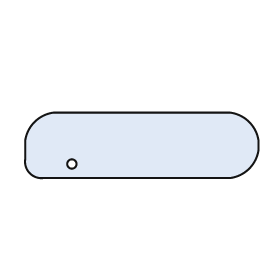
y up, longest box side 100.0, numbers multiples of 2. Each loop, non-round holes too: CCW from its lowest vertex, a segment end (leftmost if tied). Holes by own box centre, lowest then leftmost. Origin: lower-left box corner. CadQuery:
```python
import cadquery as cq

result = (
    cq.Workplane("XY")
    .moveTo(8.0, 0.0)
    .lineTo(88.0, 0.0)
    .threePointArc((96.0, 4.0), (100.0, 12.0))
    .lineTo(100.0, 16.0)
    .threePointArc((96.0, 24.0), (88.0, 28.0))
    .lineTo(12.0, 28.0)
    .threePointArc((4.0, 24.0), (0.0, 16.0))
    .lineTo(0.0, 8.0)
    .threePointArc((2.0, 2.0), (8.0, 0.0))
    .close()
    .moveTo(20.0, 6.0)
    .circle(2.0)
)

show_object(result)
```